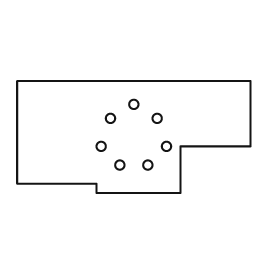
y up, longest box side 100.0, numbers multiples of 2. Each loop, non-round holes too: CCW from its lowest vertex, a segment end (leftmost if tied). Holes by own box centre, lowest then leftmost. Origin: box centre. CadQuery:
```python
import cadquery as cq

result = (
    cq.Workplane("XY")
    .moveTo(-16.0, -24.0)
    .lineTo(20.0, -24.0)
    .lineTo(20.0, -4.0)
    .lineTo(50.0, -4.0)
    .lineTo(50.0, 24.0)
    .lineTo(-50.0, 24.0)
    .lineTo(-50.0, -20.0)
    .lineTo(-16.0, -20.0)
    .close()
    .moveTo(-6.0, -12.0)
    .circle(2.0)
    .moveTo(6.0, -12.0)
    .circle(2.0)
    .moveTo(-14.0, -4.0)
    .circle(2.0)
    .moveTo(14.0, -4.0)
    .circle(2.0)
    .moveTo(-10.0, 8.0)
    .circle(2.0)
    .moveTo(10.0, 8.0)
    .circle(2.0)
    .moveTo(0.0, 14.0)
    .circle(2.0)
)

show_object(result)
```